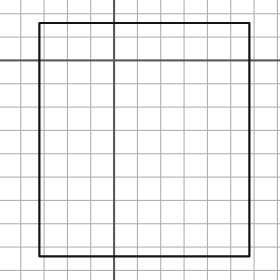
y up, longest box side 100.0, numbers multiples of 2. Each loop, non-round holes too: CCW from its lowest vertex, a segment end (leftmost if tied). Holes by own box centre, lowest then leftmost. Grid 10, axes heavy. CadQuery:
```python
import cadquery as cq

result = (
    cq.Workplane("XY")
    .moveTo(-32.0, -84.0)
    .lineTo(58.0, -84.0)
    .lineTo(58.0, 16.0)
    .lineTo(-32.0, 16.0)
    .close()
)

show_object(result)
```